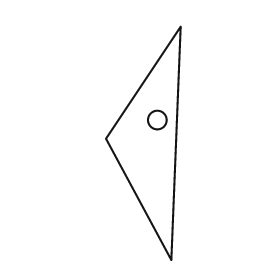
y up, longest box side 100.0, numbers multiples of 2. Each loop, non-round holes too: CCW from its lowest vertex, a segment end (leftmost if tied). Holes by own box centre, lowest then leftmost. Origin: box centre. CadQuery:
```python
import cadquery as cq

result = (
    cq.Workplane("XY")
    .moveTo(12.0, -50.0)
    .lineTo(16.0, 50.0)
    .lineTo(-16.0, 2.0)
    .close()
    .moveTo(6.0, 10.0)
    .circle(4.0)
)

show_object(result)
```